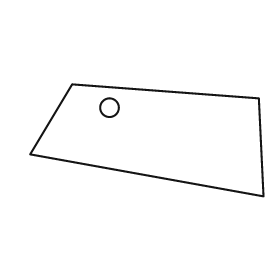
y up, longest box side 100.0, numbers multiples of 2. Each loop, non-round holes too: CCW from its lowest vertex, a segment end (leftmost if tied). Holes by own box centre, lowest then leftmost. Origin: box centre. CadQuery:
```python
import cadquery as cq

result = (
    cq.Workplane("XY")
    .moveTo(50.0, -24.0)
    .lineTo(48.0, 18.0)
    .lineTo(-32.0, 24.0)
    .lineTo(-50.0, -6.0)
    .close()
    .moveTo(-16.0, 14.0)
    .circle(4.0)
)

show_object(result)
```